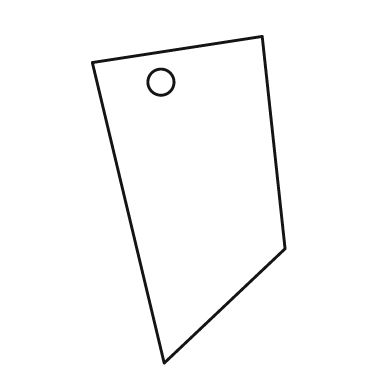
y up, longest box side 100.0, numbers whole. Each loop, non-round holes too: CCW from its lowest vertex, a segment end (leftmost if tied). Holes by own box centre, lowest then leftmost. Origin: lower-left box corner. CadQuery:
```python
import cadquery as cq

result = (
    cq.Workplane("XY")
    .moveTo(22.0, 0.0)
    .lineTo(59.0, 35.0)
    .lineTo(52.0, 100.0)
    .lineTo(0.0, 92.0)
    .close()
    .moveTo(21.0, 86.0)
    .circle(4.0)
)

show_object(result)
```